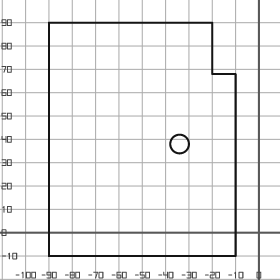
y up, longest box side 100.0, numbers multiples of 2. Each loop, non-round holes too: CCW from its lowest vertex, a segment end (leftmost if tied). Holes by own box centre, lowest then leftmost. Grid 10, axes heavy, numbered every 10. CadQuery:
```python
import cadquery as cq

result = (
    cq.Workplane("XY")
    .moveTo(-90.0, -10.0)
    .lineTo(-10.0, -10.0)
    .lineTo(-10.0, 68.0)
    .lineTo(-20.0, 68.0)
    .lineTo(-20.0, 90.0)
    .lineTo(-90.0, 90.0)
    .close()
    .moveTo(-34.0, 38.0)
    .circle(4.0)
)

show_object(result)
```